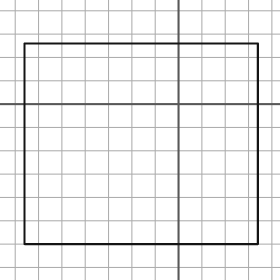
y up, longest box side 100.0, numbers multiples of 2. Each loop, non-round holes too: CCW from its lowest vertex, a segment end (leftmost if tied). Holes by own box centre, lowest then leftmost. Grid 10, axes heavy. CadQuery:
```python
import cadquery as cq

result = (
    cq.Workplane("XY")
    .moveTo(-66.0, -60.0)
    .lineTo(34.0, -60.0)
    .lineTo(34.0, 26.0)
    .lineTo(-66.0, 26.0)
    .close()
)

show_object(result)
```